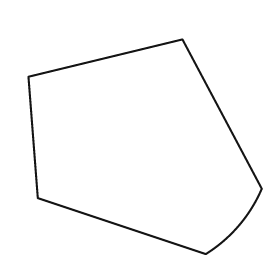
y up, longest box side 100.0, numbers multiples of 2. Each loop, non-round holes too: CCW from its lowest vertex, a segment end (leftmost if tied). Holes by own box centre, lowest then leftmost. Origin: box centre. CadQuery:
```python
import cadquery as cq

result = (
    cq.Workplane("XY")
    .moveTo(26.0, -46.0)
    .threePointArc((40.0, -34.0), (50.0, -18.0))
    .lineTo(16.0, 46.0)
    .lineTo(-50.0, 30.0)
    .lineTo(-46.0, -22.0)
    .close()
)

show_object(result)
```